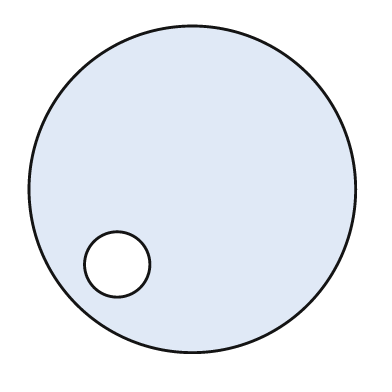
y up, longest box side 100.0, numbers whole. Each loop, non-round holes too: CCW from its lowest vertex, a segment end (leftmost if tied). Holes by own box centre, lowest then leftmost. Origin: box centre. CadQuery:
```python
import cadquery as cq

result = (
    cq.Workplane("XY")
    .moveTo(0.0, 0.0)
    .circle(50.0)
    .moveTo(-23.0, -23.0)
    .circle(10.0)
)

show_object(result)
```